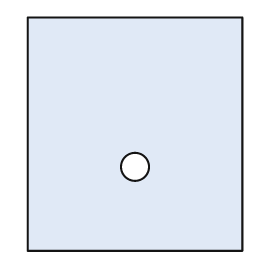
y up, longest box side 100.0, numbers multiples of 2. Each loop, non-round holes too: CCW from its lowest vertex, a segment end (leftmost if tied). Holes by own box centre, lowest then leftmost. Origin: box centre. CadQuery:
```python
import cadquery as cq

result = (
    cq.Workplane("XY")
    .moveTo(-46.0, -50.0)
    .lineTo(46.0, -50.0)
    .lineTo(46.0, 50.0)
    .lineTo(-46.0, 50.0)
    .close()
    .moveTo(0.0, -14.0)
    .circle(6.0)
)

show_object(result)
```